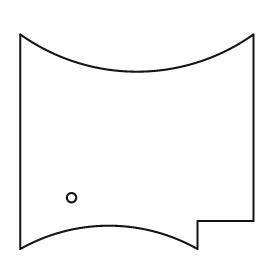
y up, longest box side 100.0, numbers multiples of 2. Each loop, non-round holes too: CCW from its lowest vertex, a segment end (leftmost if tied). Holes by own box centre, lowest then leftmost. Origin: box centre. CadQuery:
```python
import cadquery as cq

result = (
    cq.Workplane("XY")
    .moveTo(-50.0, -46.0)
    .threePointArc((-12.0, -36.0), (26.0, -46.0))
    .lineTo(26.0, -34.0)
    .lineTo(50.0, -34.0)
    .lineTo(50.0, 46.0)
    .threePointArc((0.0, 30.0), (-50.0, 46.0))
    .close()
    .moveTo(-28.0, -24.0)
    .circle(2.0)
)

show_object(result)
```